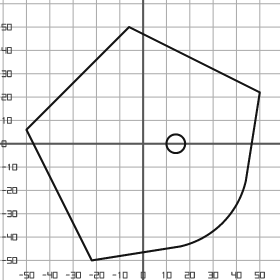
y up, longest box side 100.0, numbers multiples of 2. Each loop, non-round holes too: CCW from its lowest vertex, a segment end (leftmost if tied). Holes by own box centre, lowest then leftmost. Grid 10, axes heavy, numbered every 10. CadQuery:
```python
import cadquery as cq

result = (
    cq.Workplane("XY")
    .moveTo(-22.0, -50.0)
    .lineTo(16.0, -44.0)
    .threePointArc((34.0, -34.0), (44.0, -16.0))
    .lineTo(50.0, 22.0)
    .lineTo(-6.0, 50.0)
    .lineTo(-50.0, 6.0)
    .close()
    .moveTo(14.0, 0.0)
    .circle(4.0)
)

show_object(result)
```